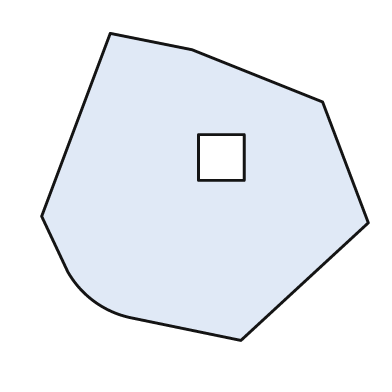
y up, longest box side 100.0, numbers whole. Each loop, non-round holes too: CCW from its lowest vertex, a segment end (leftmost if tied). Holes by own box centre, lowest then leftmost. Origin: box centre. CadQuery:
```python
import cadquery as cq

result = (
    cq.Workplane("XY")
    .moveTo(11.0, -47.0)
    .lineTo(50.0, -11.0)
    .lineTo(36.0, 26.0)
    .lineTo(-4.0, 42.0)
    .lineTo(-29.0, 47.0)
    .lineTo(-50.0, -9.0)
    .lineTo(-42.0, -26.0)
    .threePointArc((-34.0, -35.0), (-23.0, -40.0))
    .close()
    .moveTo(-2.0, 2.0)
    .lineTo(12.0, 2.0)
    .lineTo(12.0, 16.0)
    .lineTo(-2.0, 16.0)
    .close()
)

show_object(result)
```